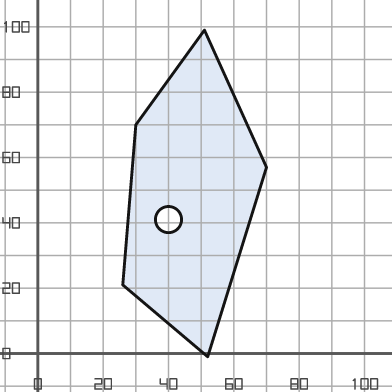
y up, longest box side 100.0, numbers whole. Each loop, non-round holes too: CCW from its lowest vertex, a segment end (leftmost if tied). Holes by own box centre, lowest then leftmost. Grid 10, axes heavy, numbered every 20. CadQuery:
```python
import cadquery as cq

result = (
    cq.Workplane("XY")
    .moveTo(52.0, -1.0)
    .lineTo(70.0, 57.0)
    .lineTo(51.0, 99.0)
    .lineTo(30.0, 70.0)
    .lineTo(26.0, 21.0)
    .close()
    .moveTo(40.0, 41.0)
    .circle(4.0)
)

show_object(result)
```